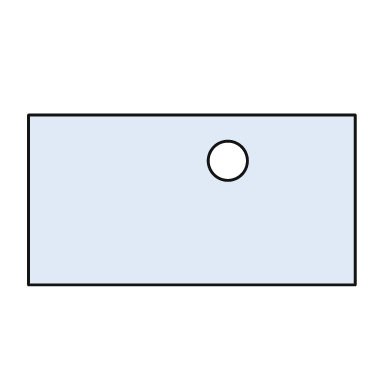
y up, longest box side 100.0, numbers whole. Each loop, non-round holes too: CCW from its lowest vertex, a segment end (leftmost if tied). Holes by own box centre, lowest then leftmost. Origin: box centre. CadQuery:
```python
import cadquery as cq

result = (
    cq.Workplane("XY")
    .moveTo(-50.0, -26.0)
    .lineTo(50.0, -26.0)
    .lineTo(50.0, 26.0)
    .lineTo(-50.0, 26.0)
    .close()
    .moveTo(11.0, 12.0)
    .circle(6.0)
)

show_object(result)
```